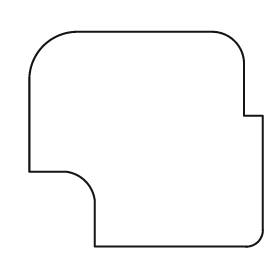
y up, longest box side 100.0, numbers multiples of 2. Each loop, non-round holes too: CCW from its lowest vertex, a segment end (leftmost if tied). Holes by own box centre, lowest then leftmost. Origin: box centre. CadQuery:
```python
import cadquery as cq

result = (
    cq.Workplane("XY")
    .moveTo(-22.0, -46.0)
    .lineTo(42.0, -46.0)
    .threePointArc((48.0, -44.0), (50.0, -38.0))
    .lineTo(50.0, 10.0)
    .lineTo(42.0, 10.0)
    .lineTo(42.0, 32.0)
    .threePointArc((38.0, 42.0), (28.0, 46.0))
    .lineTo(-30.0, 46.0)
    .threePointArc((-44.0, 40.0), (-50.0, 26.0))
    .lineTo(-50.0, -14.0)
    .lineTo(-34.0, -14.0)
    .threePointArc((-26.0, -18.0), (-22.0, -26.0))
    .close()
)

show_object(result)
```